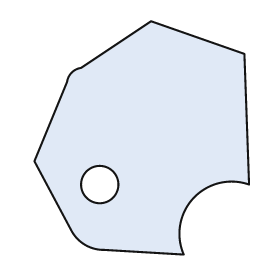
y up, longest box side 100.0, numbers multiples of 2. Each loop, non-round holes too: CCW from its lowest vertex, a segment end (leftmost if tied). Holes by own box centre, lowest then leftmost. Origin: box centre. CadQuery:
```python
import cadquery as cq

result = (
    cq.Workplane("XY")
    .moveTo(18.0, -50.0)
    .threePointArc((22.0, -26.0), (46.0, -20.0))
    .lineTo(44.0, 36.0)
    .lineTo(4.0, 50.0)
    .lineTo(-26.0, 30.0)
    .threePointArc((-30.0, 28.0), (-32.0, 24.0))
    .lineTo(-46.0, -10.0)
    .lineTo(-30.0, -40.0)
    .threePointArc((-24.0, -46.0), (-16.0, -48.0))
    .close()
    .moveTo(-18.0, -20.0)
    .circle(8.0)
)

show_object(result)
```